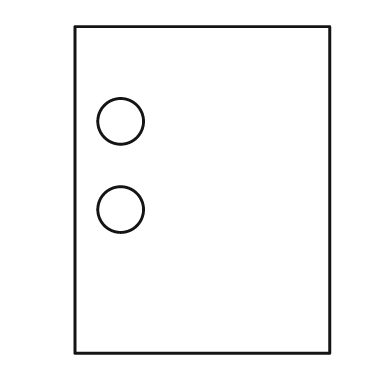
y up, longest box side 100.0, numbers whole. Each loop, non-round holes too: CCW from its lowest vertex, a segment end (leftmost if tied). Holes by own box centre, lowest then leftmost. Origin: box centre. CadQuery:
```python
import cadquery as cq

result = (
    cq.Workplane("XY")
    .moveTo(-39.0, -50.0)
    .lineTo(39.0, -50.0)
    .lineTo(39.0, 50.0)
    .lineTo(-39.0, 50.0)
    .close()
    .moveTo(-25.0, -6.0)
    .circle(7.0)
    .moveTo(-25.0, 21.0)
    .circle(7.0)
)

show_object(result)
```